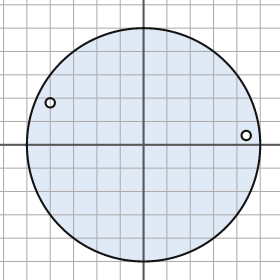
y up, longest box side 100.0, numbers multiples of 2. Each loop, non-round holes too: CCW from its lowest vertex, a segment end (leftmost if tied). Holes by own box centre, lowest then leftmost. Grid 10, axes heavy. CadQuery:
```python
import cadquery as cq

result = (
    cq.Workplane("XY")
    .moveTo(0.0, 0.0)
    .circle(50.0)
    .moveTo(44.0, 4.0)
    .circle(2.0)
    .moveTo(-40.0, 18.0)
    .circle(2.0)
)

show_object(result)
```